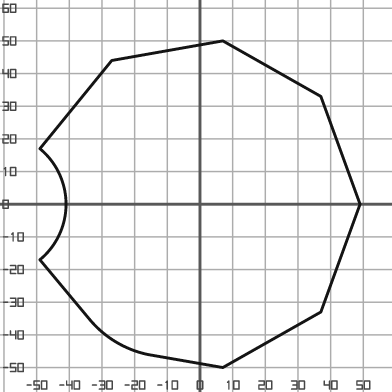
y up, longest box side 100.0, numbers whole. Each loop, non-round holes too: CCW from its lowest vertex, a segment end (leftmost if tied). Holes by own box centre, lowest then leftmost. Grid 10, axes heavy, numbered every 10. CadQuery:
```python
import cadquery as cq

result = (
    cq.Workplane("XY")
    .moveTo(7.0, -50.0)
    .lineTo(37.0, -33.0)
    .lineTo(49.0, 0.0)
    .lineTo(37.0, 33.0)
    .lineTo(7.0, 50.0)
    .lineTo(-27.0, 44.0)
    .lineTo(-49.0, 17.0)
    .threePointArc((-41.0, 0.0), (-49.0, -17.0))
    .lineTo(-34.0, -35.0)
    .threePointArc((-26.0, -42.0), (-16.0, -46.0))
    .close()
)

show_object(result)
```